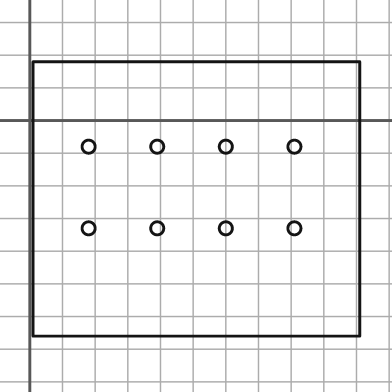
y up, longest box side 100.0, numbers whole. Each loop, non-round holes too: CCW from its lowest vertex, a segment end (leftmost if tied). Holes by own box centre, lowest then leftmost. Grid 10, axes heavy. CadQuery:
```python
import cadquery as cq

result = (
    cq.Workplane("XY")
    .moveTo(1.0, -66.0)
    .lineTo(101.0, -66.0)
    .lineTo(101.0, 18.0)
    .lineTo(1.0, 18.0)
    .close()
    .moveTo(18.0, -33.0)
    .circle(2.0)
    .moveTo(39.0, -33.0)
    .circle(2.0)
    .moveTo(60.0, -33.0)
    .circle(2.0)
    .moveTo(81.0, -33.0)
    .circle(2.0)
    .moveTo(18.0, -8.0)
    .circle(2.0)
    .moveTo(39.0, -8.0)
    .circle(2.0)
    .moveTo(60.0, -8.0)
    .circle(2.0)
    .moveTo(81.0, -8.0)
    .circle(2.0)
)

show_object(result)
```